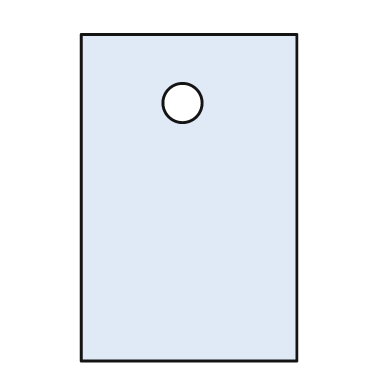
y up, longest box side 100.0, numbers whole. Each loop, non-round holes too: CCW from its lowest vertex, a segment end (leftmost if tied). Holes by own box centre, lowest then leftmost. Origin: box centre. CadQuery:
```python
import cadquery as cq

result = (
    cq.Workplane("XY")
    .moveTo(-33.0, -50.0)
    .lineTo(33.0, -50.0)
    .lineTo(33.0, 50.0)
    .lineTo(-33.0, 50.0)
    .close()
    .moveTo(-2.0, 29.0)
    .circle(6.0)
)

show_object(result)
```